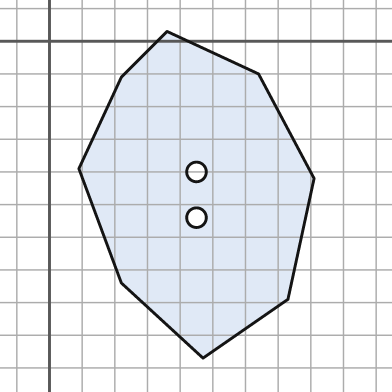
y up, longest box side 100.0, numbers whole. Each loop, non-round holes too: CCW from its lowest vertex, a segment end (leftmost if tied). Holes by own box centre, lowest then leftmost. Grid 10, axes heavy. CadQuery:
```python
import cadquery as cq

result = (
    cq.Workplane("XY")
    .moveTo(47.0, -97.0)
    .lineTo(73.0, -79.0)
    .lineTo(81.0, -42.0)
    .lineTo(64.0, -10.0)
    .lineTo(36.0, 3.0)
    .lineTo(22.0, -11.0)
    .lineTo(9.0, -39.0)
    .lineTo(22.0, -74.0)
    .close()
    .moveTo(45.0, -54.0)
    .circle(3.0)
    .moveTo(45.0, -40.0)
    .circle(3.0)
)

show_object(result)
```